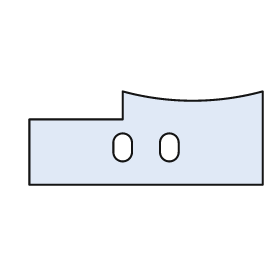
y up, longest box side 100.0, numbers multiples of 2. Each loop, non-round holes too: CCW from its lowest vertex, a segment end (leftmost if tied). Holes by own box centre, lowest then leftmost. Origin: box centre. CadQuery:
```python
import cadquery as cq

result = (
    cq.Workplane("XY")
    .moveTo(-50.0, -20.0)
    .lineTo(50.0, -20.0)
    .lineTo(50.0, 20.0)
    .threePointArc((20.0, 16.0), (-10.0, 20.0))
    .lineTo(-10.0, 8.0)
    .lineTo(-50.0, 8.0)
    .close()
    .moveTo(-14.0, -6.0)
    .threePointArc((-10.0, -10.0), (-6.0, -6.0))
    .lineTo(-6.0, -2.0)
    .threePointArc((-10.0, 2.0), (-14.0, -2.0))
    .close()
    .moveTo(6.0, -6.0)
    .threePointArc((10.0, -10.0), (14.0, -6.0))
    .lineTo(14.0, -2.0)
    .threePointArc((10.0, 2.0), (6.0, -2.0))
    .close()
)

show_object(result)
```